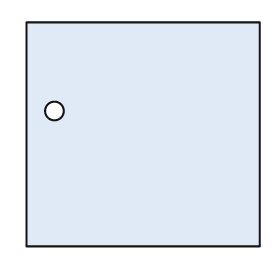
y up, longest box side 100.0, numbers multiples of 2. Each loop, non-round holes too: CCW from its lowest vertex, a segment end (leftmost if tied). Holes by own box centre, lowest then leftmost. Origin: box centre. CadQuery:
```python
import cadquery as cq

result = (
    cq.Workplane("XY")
    .moveTo(-50.0, -48.0)
    .lineTo(50.0, -48.0)
    .lineTo(50.0, 48.0)
    .lineTo(-50.0, 48.0)
    .close()
    .moveTo(-38.0, 10.0)
    .circle(4.0)
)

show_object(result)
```